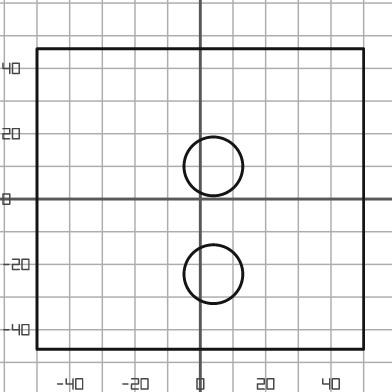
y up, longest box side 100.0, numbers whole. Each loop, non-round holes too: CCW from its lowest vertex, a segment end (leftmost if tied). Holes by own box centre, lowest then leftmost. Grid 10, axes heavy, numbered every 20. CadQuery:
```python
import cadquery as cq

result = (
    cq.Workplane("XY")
    .moveTo(-50.0, -46.0)
    .lineTo(50.0, -46.0)
    .lineTo(50.0, 46.0)
    .lineTo(-50.0, 46.0)
    .close()
    .moveTo(4.0, -23.0)
    .circle(9.0)
    .moveTo(4.0, 10.0)
    .circle(9.0)
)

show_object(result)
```